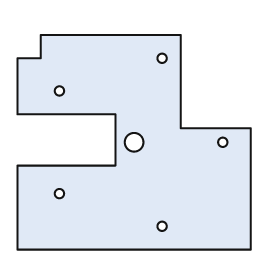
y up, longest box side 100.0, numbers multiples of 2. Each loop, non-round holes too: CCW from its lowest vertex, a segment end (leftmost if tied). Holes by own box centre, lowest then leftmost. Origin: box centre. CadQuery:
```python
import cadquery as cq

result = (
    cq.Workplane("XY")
    .moveTo(-50.0, -46.0)
    .lineTo(50.0, -46.0)
    .lineTo(50.0, 6.0)
    .lineTo(20.0, 6.0)
    .lineTo(20.0, 46.0)
    .lineTo(-40.0, 46.0)
    .lineTo(-40.0, 36.0)
    .lineTo(-50.0, 36.0)
    .lineTo(-50.0, 12.0)
    .lineTo(-8.0, 12.0)
    .lineTo(-8.0, -10.0)
    .lineTo(-50.0, -10.0)
    .close()
    .moveTo(12.0, -36.0)
    .circle(2.0)
    .moveTo(-32.0, -22.0)
    .circle(2.0)
    .moveTo(0.0, 0.0)
    .circle(4.0)
    .moveTo(38.0, 0.0)
    .circle(2.0)
    .moveTo(-32.0, 22.0)
    .circle(2.0)
    .moveTo(12.0, 36.0)
    .circle(2.0)
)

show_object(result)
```